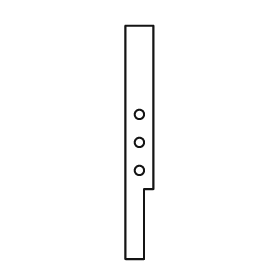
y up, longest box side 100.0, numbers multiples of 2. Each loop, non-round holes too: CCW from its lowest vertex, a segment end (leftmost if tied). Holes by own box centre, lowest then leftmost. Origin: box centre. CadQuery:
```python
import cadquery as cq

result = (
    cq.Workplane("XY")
    .moveTo(-6.0, -50.0)
    .lineTo(2.0, -50.0)
    .lineTo(2.0, -20.0)
    .lineTo(6.0, -20.0)
    .lineTo(6.0, 50.0)
    .lineTo(-6.0, 50.0)
    .close()
    .moveTo(0.0, -12.0)
    .circle(2.0)
    .moveTo(0.0, 0.0)
    .circle(2.0)
    .moveTo(0.0, 12.0)
    .circle(2.0)
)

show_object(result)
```